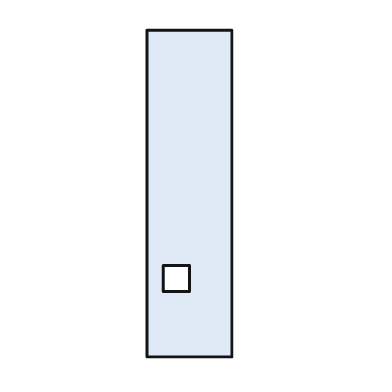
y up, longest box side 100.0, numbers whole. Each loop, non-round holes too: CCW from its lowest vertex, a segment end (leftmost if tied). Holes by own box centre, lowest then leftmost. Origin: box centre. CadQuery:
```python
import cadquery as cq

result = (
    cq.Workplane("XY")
    .moveTo(-13.0, -50.0)
    .lineTo(13.0, -50.0)
    .lineTo(13.0, 50.0)
    .lineTo(-13.0, 50.0)
    .close()
    .moveTo(-8.0, -30.0)
    .lineTo(0.0, -30.0)
    .lineTo(0.0, -22.0)
    .lineTo(-8.0, -22.0)
    .close()
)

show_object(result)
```